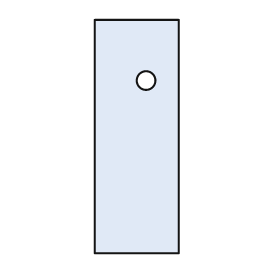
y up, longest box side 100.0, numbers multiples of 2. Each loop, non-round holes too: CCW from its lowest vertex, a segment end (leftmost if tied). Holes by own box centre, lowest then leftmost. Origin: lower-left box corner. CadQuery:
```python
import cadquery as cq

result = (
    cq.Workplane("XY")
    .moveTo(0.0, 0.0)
    .lineTo(36.0, 0.0)
    .lineTo(36.0, 100.0)
    .lineTo(0.0, 100.0)
    .close()
    .moveTo(22.0, 74.0)
    .circle(4.0)
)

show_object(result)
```